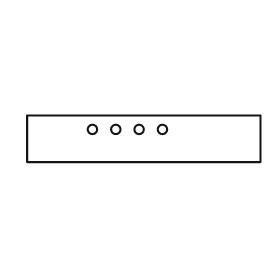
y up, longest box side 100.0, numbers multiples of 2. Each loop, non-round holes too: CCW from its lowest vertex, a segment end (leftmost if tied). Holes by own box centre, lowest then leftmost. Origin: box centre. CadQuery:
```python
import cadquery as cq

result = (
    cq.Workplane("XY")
    .moveTo(-50.0, -10.0)
    .lineTo(50.0, -10.0)
    .lineTo(50.0, 10.0)
    .lineTo(-50.0, 10.0)
    .close()
    .moveTo(-22.0, 4.0)
    .circle(2.0)
    .moveTo(-12.0, 4.0)
    .circle(2.0)
    .moveTo(-2.0, 4.0)
    .circle(2.0)
    .moveTo(8.0, 4.0)
    .circle(2.0)
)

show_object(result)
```